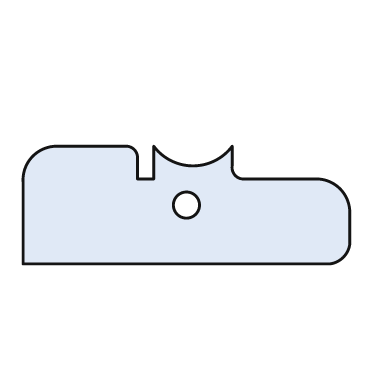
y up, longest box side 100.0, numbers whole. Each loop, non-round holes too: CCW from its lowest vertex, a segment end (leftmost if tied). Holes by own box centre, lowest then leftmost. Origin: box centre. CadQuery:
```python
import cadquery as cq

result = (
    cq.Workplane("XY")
    .moveTo(-50.0, -18.0)
    .lineTo(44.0, -18.0)
    .threePointArc((48.0, -16.0), (50.0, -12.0))
    .lineTo(50.0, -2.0)
    .threePointArc((47.0, 5.0), (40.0, 8.0))
    .lineTo(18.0, 8.0)
    .threePointArc((15.0, 9.0), (14.0, 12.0))
    .lineTo(14.0, 18.0)
    .threePointArc((2.0, 12.0), (-10.0, 18.0))
    .lineTo(-10.0, 8.0)
    .lineTo(-15.0, 8.0)
    .lineTo(-15.0, 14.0)
    .threePointArc((-16.0, 17.0), (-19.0, 18.0))
    .lineTo(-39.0, 18.0)
    .threePointArc((-47.0, 15.0), (-50.0, 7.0))
    .close()
    .moveTo(0.0, 0.0)
    .circle(4.0)
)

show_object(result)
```